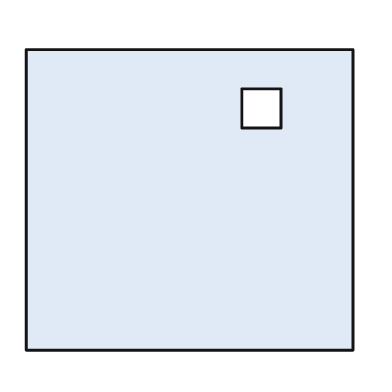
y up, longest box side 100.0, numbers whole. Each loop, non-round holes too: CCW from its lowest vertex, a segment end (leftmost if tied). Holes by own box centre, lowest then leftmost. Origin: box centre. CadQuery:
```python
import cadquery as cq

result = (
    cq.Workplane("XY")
    .moveTo(-50.0, -46.0)
    .lineTo(50.0, -46.0)
    .lineTo(50.0, 46.0)
    .lineTo(-50.0, 46.0)
    .close()
    .moveTo(16.0, 22.0)
    .lineTo(28.0, 22.0)
    .lineTo(28.0, 34.0)
    .lineTo(16.0, 34.0)
    .close()
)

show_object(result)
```